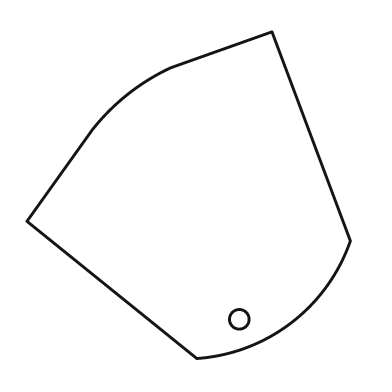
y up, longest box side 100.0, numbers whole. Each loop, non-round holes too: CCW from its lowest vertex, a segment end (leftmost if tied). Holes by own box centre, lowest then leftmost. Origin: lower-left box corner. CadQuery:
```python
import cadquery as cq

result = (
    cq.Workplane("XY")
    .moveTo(52.0, 0.0)
    .threePointArc((81.0, 11.0), (99.0, 36.0))
    .lineTo(75.0, 100.0)
    .lineTo(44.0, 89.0)
    .threePointArc((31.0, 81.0), (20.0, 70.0))
    .lineTo(0.0, 42.0)
    .close()
    .moveTo(65.0, 12.0)
    .circle(3.0)
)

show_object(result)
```